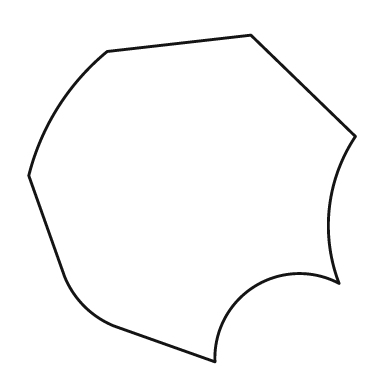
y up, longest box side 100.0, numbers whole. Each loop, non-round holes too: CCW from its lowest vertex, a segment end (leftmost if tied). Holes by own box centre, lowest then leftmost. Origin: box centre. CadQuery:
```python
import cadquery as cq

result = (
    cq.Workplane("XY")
    .moveTo(7.0, -50.0)
    .threePointArc((19.0, -27.0), (45.0, -26.0))
    .threePointArc((42.0, -3.0), (50.0, 19.0))
    .lineTo(18.0, 50.0)
    .lineTo(-26.0, 45.0)
    .threePointArc((-41.0, 28.0), (-50.0, 7.0))
    .lineTo(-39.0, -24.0)
    .threePointArc((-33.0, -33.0), (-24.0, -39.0))
    .close()
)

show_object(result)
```